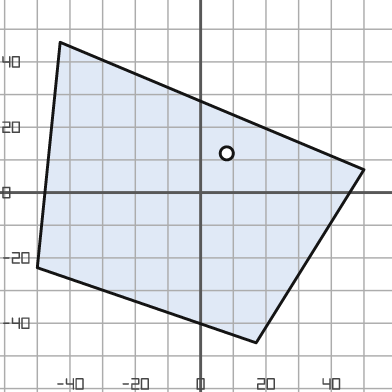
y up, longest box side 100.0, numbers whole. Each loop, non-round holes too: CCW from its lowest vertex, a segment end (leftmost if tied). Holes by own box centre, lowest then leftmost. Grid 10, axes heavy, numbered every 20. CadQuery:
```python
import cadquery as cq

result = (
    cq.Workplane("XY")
    .moveTo(17.0, -46.0)
    .lineTo(50.0, 7.0)
    .lineTo(-43.0, 46.0)
    .lineTo(-50.0, -23.0)
    .close()
    .moveTo(8.0, 12.0)
    .circle(2.0)
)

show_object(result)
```